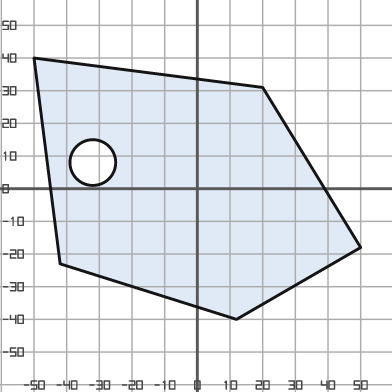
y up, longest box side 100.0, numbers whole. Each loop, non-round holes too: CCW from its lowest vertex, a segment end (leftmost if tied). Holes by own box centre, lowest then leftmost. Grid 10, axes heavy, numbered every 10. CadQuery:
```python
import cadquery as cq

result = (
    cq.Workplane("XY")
    .moveTo(12.0, -40.0)
    .lineTo(50.0, -18.0)
    .lineTo(20.0, 31.0)
    .lineTo(-50.0, 40.0)
    .lineTo(-42.0, -23.0)
    .close()
    .moveTo(-32.0, 8.0)
    .circle(7.0)
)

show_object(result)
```